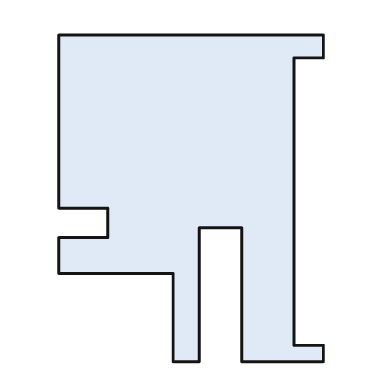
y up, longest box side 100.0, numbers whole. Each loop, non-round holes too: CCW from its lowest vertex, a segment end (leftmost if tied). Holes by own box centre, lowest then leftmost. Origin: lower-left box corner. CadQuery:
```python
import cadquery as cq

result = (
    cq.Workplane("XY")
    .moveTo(35.0, 0.0)
    .lineTo(43.0, 0.0)
    .lineTo(43.0, 41.0)
    .lineTo(56.0, 41.0)
    .lineTo(56.0, 0.0)
    .lineTo(81.0, 0.0)
    .lineTo(81.0, 5.0)
    .lineTo(72.0, 5.0)
    .lineTo(72.0, 93.0)
    .lineTo(81.0, 93.0)
    .lineTo(81.0, 100.0)
    .lineTo(0.0, 100.0)
    .lineTo(0.0, 47.0)
    .lineTo(15.0, 47.0)
    .lineTo(15.0, 38.0)
    .lineTo(0.0, 38.0)
    .lineTo(0.0, 27.0)
    .lineTo(35.0, 27.0)
    .close()
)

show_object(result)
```